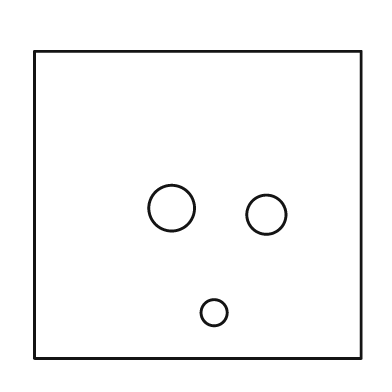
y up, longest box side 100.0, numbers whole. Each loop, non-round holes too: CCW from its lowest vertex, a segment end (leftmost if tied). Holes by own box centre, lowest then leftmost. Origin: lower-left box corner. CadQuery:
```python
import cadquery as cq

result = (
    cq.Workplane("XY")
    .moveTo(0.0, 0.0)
    .lineTo(100.0, 0.0)
    .lineTo(100.0, 94.0)
    .lineTo(0.0, 94.0)
    .close()
    .moveTo(55.0, 14.0)
    .circle(4.0)
    .moveTo(71.0, 44.0)
    .circle(6.0)
    .moveTo(42.0, 46.0)
    .circle(7.0)
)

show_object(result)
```